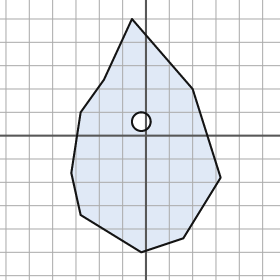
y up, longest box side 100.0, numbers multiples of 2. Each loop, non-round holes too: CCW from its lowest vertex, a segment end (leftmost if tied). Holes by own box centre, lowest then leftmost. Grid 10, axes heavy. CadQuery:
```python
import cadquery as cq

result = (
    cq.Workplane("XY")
    .moveTo(-2.0, -50.0)
    .lineTo(16.0, -44.0)
    .lineTo(32.0, -18.0)
    .lineTo(20.0, 20.0)
    .lineTo(-6.0, 50.0)
    .lineTo(-18.0, 24.0)
    .lineTo(-28.0, 10.0)
    .lineTo(-32.0, -16.0)
    .lineTo(-28.0, -34.0)
    .close()
    .moveTo(-2.0, 6.0)
    .circle(4.0)
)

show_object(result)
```